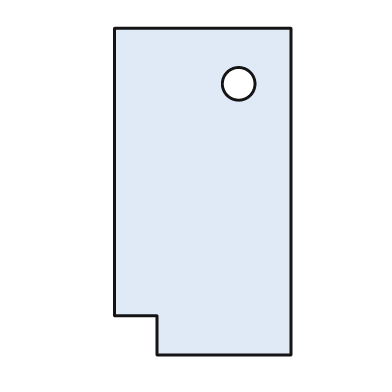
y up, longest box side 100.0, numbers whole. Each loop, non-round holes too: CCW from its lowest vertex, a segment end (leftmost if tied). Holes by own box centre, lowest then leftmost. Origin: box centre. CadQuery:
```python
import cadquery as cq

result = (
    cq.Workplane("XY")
    .moveTo(-14.0, -50.0)
    .lineTo(27.0, -50.0)
    .lineTo(27.0, 50.0)
    .lineTo(-27.0, 50.0)
    .lineTo(-27.0, -38.0)
    .lineTo(-14.0, -38.0)
    .close()
    .moveTo(11.0, 33.0)
    .circle(5.0)
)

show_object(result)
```